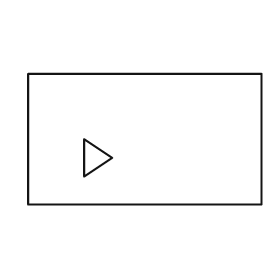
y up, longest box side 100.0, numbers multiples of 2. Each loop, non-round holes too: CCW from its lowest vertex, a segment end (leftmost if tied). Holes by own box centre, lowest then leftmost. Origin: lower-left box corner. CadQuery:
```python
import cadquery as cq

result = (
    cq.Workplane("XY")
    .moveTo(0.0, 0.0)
    .lineTo(100.0, 0.0)
    .lineTo(100.0, 56.0)
    .lineTo(0.0, 56.0)
    .close()
    .moveTo(24.0, 12.0)
    .lineTo(36.0, 20.0)
    .lineTo(24.0, 28.0)
    .close()
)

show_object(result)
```